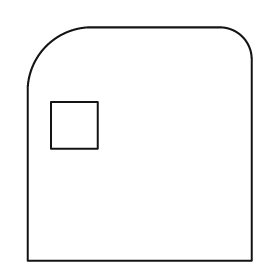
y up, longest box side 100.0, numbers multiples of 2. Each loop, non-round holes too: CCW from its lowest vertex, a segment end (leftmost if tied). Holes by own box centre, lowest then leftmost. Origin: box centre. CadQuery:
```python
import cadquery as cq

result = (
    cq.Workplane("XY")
    .moveTo(-48.0, -50.0)
    .lineTo(48.0, -50.0)
    .lineTo(48.0, 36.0)
    .threePointArc((44.0, 46.0), (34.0, 50.0))
    .lineTo(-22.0, 50.0)
    .threePointArc((-40.0, 42.0), (-48.0, 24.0))
    .close()
    .moveTo(-38.0, -2.0)
    .lineTo(-18.0, -2.0)
    .lineTo(-18.0, 18.0)
    .lineTo(-38.0, 18.0)
    .close()
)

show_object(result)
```